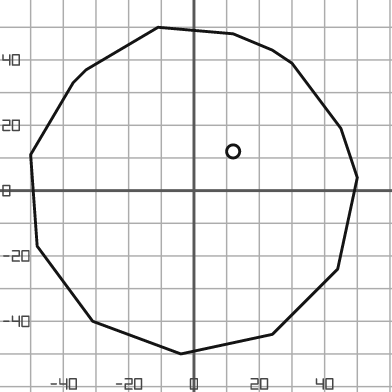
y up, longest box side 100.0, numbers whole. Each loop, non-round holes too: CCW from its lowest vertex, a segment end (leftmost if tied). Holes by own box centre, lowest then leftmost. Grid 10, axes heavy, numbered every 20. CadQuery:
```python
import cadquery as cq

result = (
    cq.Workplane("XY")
    .moveTo(-4.0, -50.0)
    .lineTo(24.0, -44.0)
    .lineTo(44.0, -24.0)
    .lineTo(50.0, 4.0)
    .lineTo(45.0, 19.0)
    .lineTo(30.0, 39.0)
    .lineTo(24.0, 43.0)
    .lineTo(12.0, 48.0)
    .lineTo(-11.0, 50.0)
    .lineTo(-33.0, 37.0)
    .lineTo(-37.0, 33.0)
    .lineTo(-50.0, 11.0)
    .lineTo(-48.0, -17.0)
    .lineTo(-31.0, -40.0)
    .close()
    .moveTo(12.0, 12.0)
    .circle(2.0)
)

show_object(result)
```